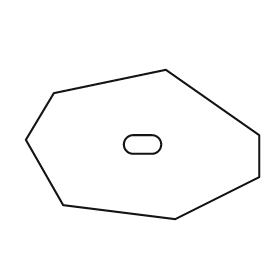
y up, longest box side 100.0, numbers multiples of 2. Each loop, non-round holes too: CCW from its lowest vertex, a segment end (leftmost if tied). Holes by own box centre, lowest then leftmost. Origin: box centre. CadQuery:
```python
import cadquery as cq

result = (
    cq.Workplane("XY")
    .moveTo(14.0, -32.0)
    .lineTo(50.0, -14.0)
    .lineTo(50.0, 4.0)
    .lineTo(10.0, 32.0)
    .lineTo(-38.0, 22.0)
    .lineTo(-50.0, 2.0)
    .lineTo(-34.0, -26.0)
    .close()
    .moveTo(-4.0, -4.0)
    .lineTo(4.0, -4.0)
    .threePointArc((8.0, 0.0), (4.0, 4.0))
    .lineTo(-4.0, 4.0)
    .threePointArc((-8.0, 0.0), (-4.0, -4.0))
    .close()
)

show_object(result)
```